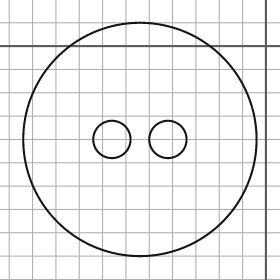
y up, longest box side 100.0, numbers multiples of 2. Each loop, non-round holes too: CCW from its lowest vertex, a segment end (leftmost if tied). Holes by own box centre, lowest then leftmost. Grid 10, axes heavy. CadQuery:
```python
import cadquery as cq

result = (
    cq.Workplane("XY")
    .moveTo(-54.0, -40.0)
    .circle(50.0)
    .moveTo(-66.0, -40.0)
    .circle(8.0)
    .moveTo(-42.0, -40.0)
    .circle(8.0)
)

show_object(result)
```